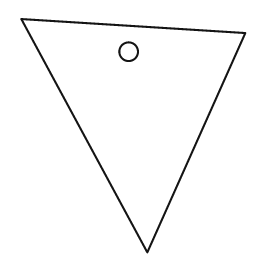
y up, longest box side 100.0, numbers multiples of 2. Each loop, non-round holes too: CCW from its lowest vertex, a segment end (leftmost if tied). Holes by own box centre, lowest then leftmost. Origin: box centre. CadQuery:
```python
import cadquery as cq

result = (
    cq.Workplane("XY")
    .moveTo(6.0, -50.0)
    .lineTo(48.0, 44.0)
    .lineTo(-48.0, 50.0)
    .close()
    .moveTo(-2.0, 36.0)
    .circle(4.0)
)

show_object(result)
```